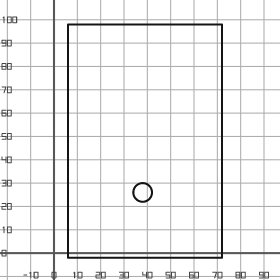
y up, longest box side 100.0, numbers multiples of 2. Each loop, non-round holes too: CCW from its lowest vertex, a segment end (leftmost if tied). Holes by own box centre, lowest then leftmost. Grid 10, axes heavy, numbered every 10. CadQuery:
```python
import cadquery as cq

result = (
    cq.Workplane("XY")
    .moveTo(6.0, -2.0)
    .lineTo(72.0, -2.0)
    .lineTo(72.0, 98.0)
    .lineTo(6.0, 98.0)
    .close()
    .moveTo(38.0, 26.0)
    .circle(4.0)
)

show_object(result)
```